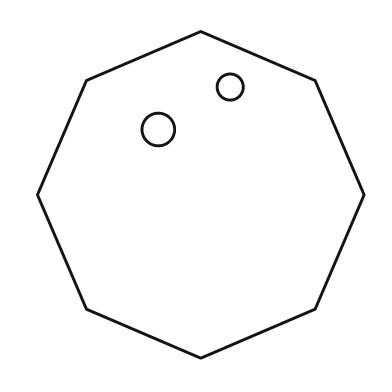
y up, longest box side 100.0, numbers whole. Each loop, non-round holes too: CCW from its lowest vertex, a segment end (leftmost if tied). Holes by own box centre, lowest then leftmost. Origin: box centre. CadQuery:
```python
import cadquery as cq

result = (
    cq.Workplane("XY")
    .moveTo(0.0, -50.0)
    .lineTo(35.0, -35.0)
    .lineTo(50.0, 0.0)
    .lineTo(35.0, 35.0)
    .lineTo(0.0, 50.0)
    .lineTo(-35.0, 35.0)
    .lineTo(-50.0, 0.0)
    .lineTo(-35.0, -35.0)
    .close()
    .moveTo(-13.0, 20.0)
    .circle(5.0)
    .moveTo(9.0, 33.0)
    .circle(4.0)
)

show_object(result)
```